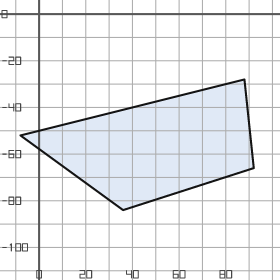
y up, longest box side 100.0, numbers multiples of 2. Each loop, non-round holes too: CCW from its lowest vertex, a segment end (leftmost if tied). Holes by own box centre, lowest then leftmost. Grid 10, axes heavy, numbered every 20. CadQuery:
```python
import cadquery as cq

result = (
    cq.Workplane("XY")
    .moveTo(36.0, -84.0)
    .lineTo(92.0, -66.0)
    .lineTo(88.0, -28.0)
    .lineTo(-8.0, -52.0)
    .close()
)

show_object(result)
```